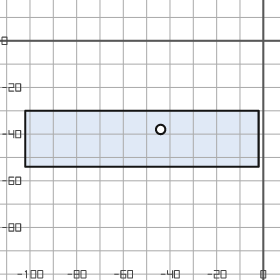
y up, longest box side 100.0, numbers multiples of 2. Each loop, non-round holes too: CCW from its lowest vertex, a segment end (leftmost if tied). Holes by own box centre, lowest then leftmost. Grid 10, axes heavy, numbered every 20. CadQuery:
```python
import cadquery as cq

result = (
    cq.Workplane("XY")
    .moveTo(-102.0, -54.0)
    .lineTo(-2.0, -54.0)
    .lineTo(-2.0, -30.0)
    .lineTo(-102.0, -30.0)
    .close()
    .moveTo(-44.0, -38.0)
    .circle(2.0)
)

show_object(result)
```